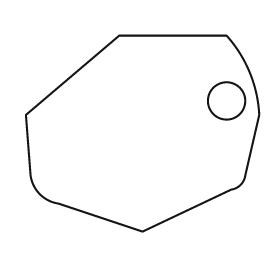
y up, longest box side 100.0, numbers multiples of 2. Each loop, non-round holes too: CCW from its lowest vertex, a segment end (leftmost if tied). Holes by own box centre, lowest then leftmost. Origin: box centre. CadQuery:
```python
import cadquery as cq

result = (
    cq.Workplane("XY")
    .moveTo(0.0, -42.0)
    .lineTo(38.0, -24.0)
    .threePointArc((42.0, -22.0), (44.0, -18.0))
    .lineTo(50.0, 8.0)
    .threePointArc((46.0, 26.0), (36.0, 42.0))
    .lineTo(-10.0, 42.0)
    .lineTo(-50.0, 8.0)
    .lineTo(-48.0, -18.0)
    .threePointArc((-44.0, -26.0), (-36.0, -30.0))
    .close()
    .moveTo(36.0, 14.0)
    .circle(8.0)
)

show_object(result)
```